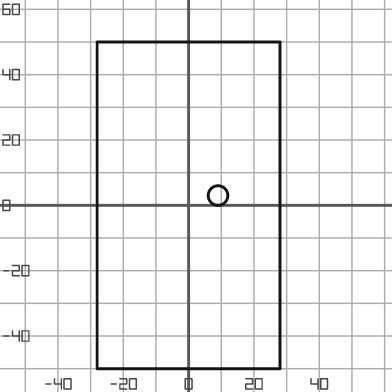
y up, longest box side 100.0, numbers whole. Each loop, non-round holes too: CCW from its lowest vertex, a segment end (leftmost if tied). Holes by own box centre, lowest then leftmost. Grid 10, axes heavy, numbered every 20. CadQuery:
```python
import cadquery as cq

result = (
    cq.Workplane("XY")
    .moveTo(-28.0, -50.0)
    .lineTo(28.0, -50.0)
    .lineTo(28.0, 50.0)
    .lineTo(-28.0, 50.0)
    .close()
    .moveTo(9.0, 3.0)
    .circle(3.0)
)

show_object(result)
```